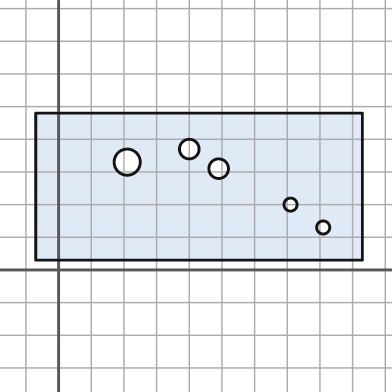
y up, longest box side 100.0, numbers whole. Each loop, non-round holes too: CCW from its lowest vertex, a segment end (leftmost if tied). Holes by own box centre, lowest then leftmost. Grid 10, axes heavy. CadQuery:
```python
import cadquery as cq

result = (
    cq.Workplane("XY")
    .moveTo(-7.0, 3.0)
    .lineTo(93.0, 3.0)
    .lineTo(93.0, 48.0)
    .lineTo(-7.0, 48.0)
    .close()
    .moveTo(81.0, 13.0)
    .circle(2.0)
    .moveTo(71.0, 20.0)
    .circle(2.0)
    .moveTo(49.0, 31.0)
    .circle(3.0)
    .moveTo(21.0, 33.0)
    .circle(4.0)
    .moveTo(40.0, 37.0)
    .circle(3.0)
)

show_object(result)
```